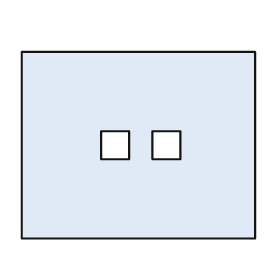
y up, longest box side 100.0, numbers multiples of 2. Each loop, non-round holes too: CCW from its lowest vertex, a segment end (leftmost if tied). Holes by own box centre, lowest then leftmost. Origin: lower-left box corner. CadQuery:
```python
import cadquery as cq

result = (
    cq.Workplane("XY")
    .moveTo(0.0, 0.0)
    .lineTo(100.0, 0.0)
    .lineTo(100.0, 80.0)
    .lineTo(0.0, 80.0)
    .close()
    .moveTo(34.0, 34.0)
    .lineTo(46.0, 34.0)
    .lineTo(46.0, 46.0)
    .lineTo(34.0, 46.0)
    .close()
    .moveTo(56.0, 34.0)
    .lineTo(68.0, 34.0)
    .lineTo(68.0, 46.0)
    .lineTo(56.0, 46.0)
    .close()
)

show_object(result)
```